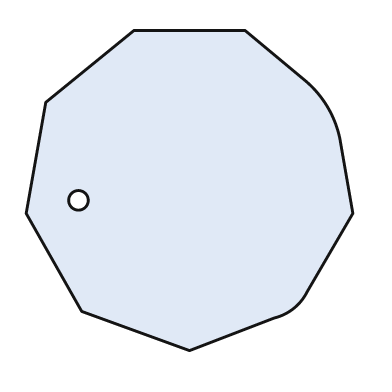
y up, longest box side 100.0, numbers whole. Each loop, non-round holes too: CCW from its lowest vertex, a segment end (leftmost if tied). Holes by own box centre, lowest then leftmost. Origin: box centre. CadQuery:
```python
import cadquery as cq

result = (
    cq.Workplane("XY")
    .moveTo(0.0, -49.0)
    .lineTo(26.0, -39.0)
    .threePointArc((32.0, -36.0), (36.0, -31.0))
    .lineTo(50.0, -7.0)
    .lineTo(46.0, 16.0)
    .threePointArc((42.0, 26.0), (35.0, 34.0))
    .lineTo(17.0, 49.0)
    .lineTo(-17.0, 49.0)
    .lineTo(-44.0, 27.0)
    .lineTo(-50.0, -7.0)
    .lineTo(-33.0, -37.0)
    .close()
    .moveTo(-34.0, -3.0)
    .circle(3.0)
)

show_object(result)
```